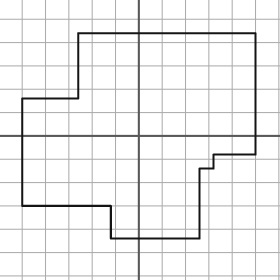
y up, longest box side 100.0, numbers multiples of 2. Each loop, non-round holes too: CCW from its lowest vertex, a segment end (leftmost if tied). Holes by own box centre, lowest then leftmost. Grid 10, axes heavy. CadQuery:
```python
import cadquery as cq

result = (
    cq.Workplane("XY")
    .moveTo(-12.0, -44.0)
    .lineTo(26.0, -44.0)
    .lineTo(26.0, -14.0)
    .lineTo(32.0, -14.0)
    .lineTo(32.0, -8.0)
    .lineTo(50.0, -8.0)
    .lineTo(50.0, 44.0)
    .lineTo(-26.0, 44.0)
    .lineTo(-26.0, 16.0)
    .lineTo(-50.0, 16.0)
    .lineTo(-50.0, -30.0)
    .lineTo(-12.0, -30.0)
    .close()
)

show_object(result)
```